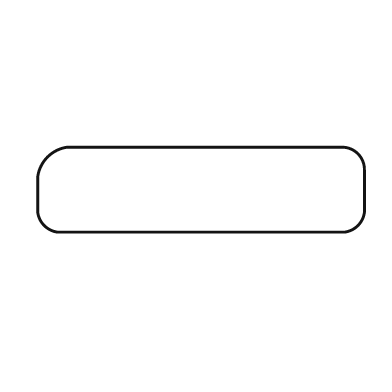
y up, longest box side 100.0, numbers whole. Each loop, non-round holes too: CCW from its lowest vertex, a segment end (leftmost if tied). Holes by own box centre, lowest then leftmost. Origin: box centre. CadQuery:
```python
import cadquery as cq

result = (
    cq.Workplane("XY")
    .moveTo(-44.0, -13.0)
    .lineTo(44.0, -13.0)
    .threePointArc((48.0, -11.0), (50.0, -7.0))
    .lineTo(50.0, 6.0)
    .threePointArc((48.0, 11.0), (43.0, 13.0))
    .lineTo(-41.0, 13.0)
    .threePointArc((-47.0, 10.0), (-50.0, 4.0))
    .lineTo(-50.0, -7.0)
    .threePointArc((-48.0, -11.0), (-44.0, -13.0))
    .close()
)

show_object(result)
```